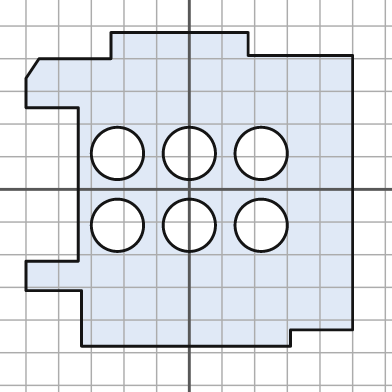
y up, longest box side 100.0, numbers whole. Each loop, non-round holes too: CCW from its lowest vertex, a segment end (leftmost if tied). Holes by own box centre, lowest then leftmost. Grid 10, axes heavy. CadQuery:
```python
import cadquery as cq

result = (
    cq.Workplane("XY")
    .moveTo(-33.0, -48.0)
    .lineTo(31.0, -48.0)
    .lineTo(31.0, -43.0)
    .lineTo(50.0, -43.0)
    .lineTo(50.0, 41.0)
    .lineTo(18.0, 41.0)
    .lineTo(18.0, 48.0)
    .lineTo(-24.0, 48.0)
    .lineTo(-24.0, 40.0)
    .lineTo(-46.0, 40.0)
    .lineTo(-50.0, 34.0)
    .lineTo(-50.0, 25.0)
    .lineTo(-34.0, 25.0)
    .lineTo(-34.0, -22.0)
    .lineTo(-50.0, -22.0)
    .lineTo(-50.0, -31.0)
    .lineTo(-33.0, -31.0)
    .close()
    .moveTo(-22.0, -11.0)
    .circle(8.0)
    .moveTo(0.0, -11.0)
    .circle(8.0)
    .moveTo(22.0, -11.0)
    .circle(8.0)
    .moveTo(-22.0, 11.0)
    .circle(8.0)
    .moveTo(0.0, 11.0)
    .circle(8.0)
    .moveTo(22.0, 11.0)
    .circle(8.0)
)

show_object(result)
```